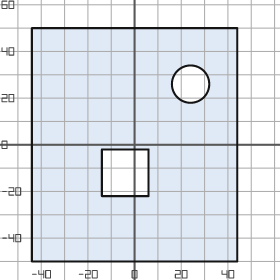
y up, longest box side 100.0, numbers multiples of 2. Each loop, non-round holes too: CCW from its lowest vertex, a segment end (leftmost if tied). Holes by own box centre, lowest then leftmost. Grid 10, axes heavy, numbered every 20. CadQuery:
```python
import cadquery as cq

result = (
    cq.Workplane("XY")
    .moveTo(-44.0, -50.0)
    .lineTo(44.0, -50.0)
    .lineTo(44.0, 50.0)
    .lineTo(-44.0, 50.0)
    .close()
    .moveTo(-14.0, -22.0)
    .lineTo(6.0, -22.0)
    .lineTo(6.0, -2.0)
    .lineTo(-14.0, -2.0)
    .close()
    .moveTo(24.0, 26.0)
    .circle(8.0)
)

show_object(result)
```